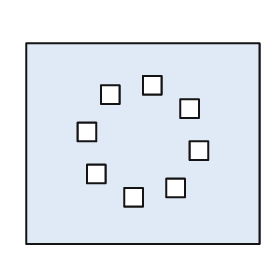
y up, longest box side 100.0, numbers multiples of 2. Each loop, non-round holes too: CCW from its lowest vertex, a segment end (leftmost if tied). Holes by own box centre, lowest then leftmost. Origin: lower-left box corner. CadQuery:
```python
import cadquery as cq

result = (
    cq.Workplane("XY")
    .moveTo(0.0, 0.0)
    .lineTo(100.0, 0.0)
    .lineTo(100.0, 86.0)
    .lineTo(0.0, 86.0)
    .close()
    .moveTo(42.0, 16.0)
    .lineTo(50.0, 16.0)
    .lineTo(50.0, 24.0)
    .lineTo(42.0, 24.0)
    .close()
    .moveTo(60.0, 20.0)
    .lineTo(68.0, 20.0)
    .lineTo(68.0, 28.0)
    .lineTo(60.0, 28.0)
    .close()
    .moveTo(26.0, 26.0)
    .lineTo(34.0, 26.0)
    .lineTo(34.0, 34.0)
    .lineTo(26.0, 34.0)
    .close()
    .moveTo(70.0, 36.0)
    .lineTo(78.0, 36.0)
    .lineTo(78.0, 44.0)
    .lineTo(70.0, 44.0)
    .close()
    .moveTo(22.0, 44.0)
    .lineTo(30.0, 44.0)
    .lineTo(30.0, 52.0)
    .lineTo(22.0, 52.0)
    .close()
    .moveTo(66.0, 54.0)
    .lineTo(74.0, 54.0)
    .lineTo(74.0, 62.0)
    .lineTo(66.0, 62.0)
    .close()
    .moveTo(32.0, 60.0)
    .lineTo(40.0, 60.0)
    .lineTo(40.0, 68.0)
    .lineTo(32.0, 68.0)
    .close()
    .moveTo(50.0, 64.0)
    .lineTo(58.0, 64.0)
    .lineTo(58.0, 72.0)
    .lineTo(50.0, 72.0)
    .close()
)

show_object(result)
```